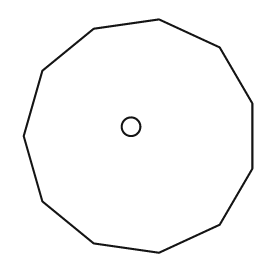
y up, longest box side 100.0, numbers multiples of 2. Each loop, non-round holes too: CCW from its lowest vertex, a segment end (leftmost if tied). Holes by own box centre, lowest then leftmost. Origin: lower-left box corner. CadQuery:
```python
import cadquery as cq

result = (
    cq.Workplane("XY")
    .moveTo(58.0, 0.0)
    .lineTo(84.0, 12.0)
    .lineTo(98.0, 36.0)
    .lineTo(98.0, 64.0)
    .lineTo(84.0, 88.0)
    .lineTo(58.0, 100.0)
    .lineTo(30.0, 96.0)
    .lineTo(8.0, 78.0)
    .lineTo(0.0, 50.0)
    .lineTo(8.0, 22.0)
    .lineTo(30.0, 4.0)
    .close()
    .moveTo(46.0, 54.0)
    .circle(4.0)
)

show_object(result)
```